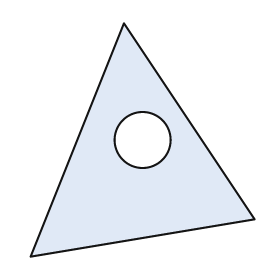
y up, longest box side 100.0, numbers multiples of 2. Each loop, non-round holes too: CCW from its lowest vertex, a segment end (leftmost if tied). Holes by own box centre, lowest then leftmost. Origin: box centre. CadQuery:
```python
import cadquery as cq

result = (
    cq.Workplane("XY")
    .moveTo(-48.0, -50.0)
    .lineTo(48.0, -34.0)
    .lineTo(-8.0, 50.0)
    .close()
    .moveTo(0.0, 0.0)
    .circle(12.0)
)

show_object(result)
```